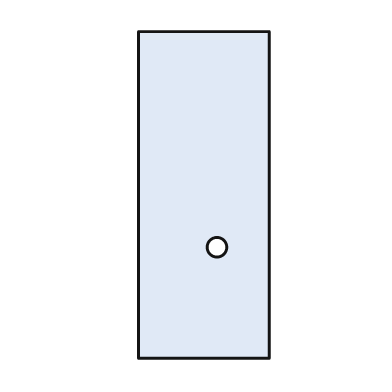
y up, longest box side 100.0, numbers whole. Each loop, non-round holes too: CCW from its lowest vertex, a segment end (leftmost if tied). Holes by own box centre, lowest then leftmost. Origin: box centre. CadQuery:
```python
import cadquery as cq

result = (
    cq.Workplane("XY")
    .moveTo(-20.0, -50.0)
    .lineTo(20.0, -50.0)
    .lineTo(20.0, 50.0)
    .lineTo(-20.0, 50.0)
    .close()
    .moveTo(4.0, -16.0)
    .circle(3.0)
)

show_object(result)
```